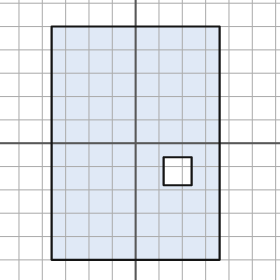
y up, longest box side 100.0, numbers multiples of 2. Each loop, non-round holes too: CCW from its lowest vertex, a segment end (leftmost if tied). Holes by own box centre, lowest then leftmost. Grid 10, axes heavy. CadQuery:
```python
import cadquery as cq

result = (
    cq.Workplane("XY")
    .moveTo(-36.0, -50.0)
    .lineTo(36.0, -50.0)
    .lineTo(36.0, 50.0)
    .lineTo(-36.0, 50.0)
    .close()
    .moveTo(12.0, -18.0)
    .lineTo(24.0, -18.0)
    .lineTo(24.0, -6.0)
    .lineTo(12.0, -6.0)
    .close()
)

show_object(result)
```